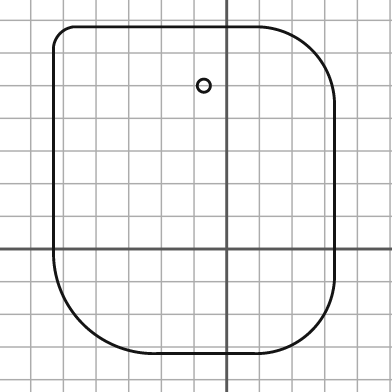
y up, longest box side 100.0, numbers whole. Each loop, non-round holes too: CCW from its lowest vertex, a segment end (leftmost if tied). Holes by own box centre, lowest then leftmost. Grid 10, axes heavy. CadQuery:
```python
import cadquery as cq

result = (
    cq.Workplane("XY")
    .moveTo(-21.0, -32.0)
    .lineTo(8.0, -32.0)
    .threePointArc((26.0, -25.0), (33.0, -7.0))
    .lineTo(33.0, 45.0)
    .threePointArc((26.0, 61.0), (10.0, 68.0))
    .lineTo(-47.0, 68.0)
    .threePointArc((-51.0, 66.0), (-53.0, 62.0))
    .lineTo(-53.0, 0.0)
    .threePointArc((-44.0, -23.0), (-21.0, -32.0))
    .close()
    .moveTo(-7.0, 50.0)
    .circle(2.0)
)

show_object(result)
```